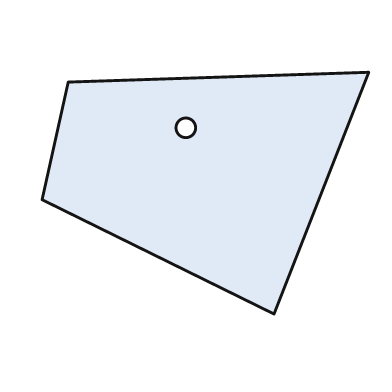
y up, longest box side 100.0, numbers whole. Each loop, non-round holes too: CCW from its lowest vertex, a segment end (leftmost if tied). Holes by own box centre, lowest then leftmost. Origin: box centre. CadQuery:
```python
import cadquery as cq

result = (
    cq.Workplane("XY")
    .moveTo(21.0, -37.0)
    .lineTo(50.0, 37.0)
    .lineTo(-42.0, 34.0)
    .lineTo(-50.0, -2.0)
    .close()
    .moveTo(-6.0, 20.0)
    .circle(3.0)
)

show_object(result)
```